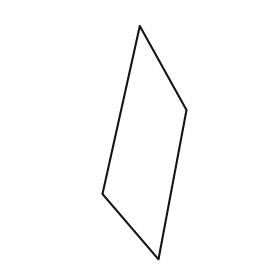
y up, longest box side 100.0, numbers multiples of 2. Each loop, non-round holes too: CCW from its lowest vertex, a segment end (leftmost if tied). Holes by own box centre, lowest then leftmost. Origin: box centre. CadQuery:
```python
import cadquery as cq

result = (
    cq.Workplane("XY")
    .moveTo(6.0, -50.0)
    .lineTo(18.0, 14.0)
    .lineTo(-2.0, 50.0)
    .lineTo(-18.0, -22.0)
    .close()
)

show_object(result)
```